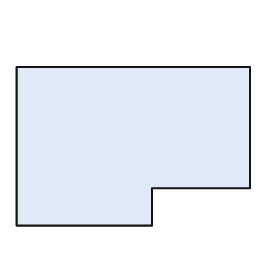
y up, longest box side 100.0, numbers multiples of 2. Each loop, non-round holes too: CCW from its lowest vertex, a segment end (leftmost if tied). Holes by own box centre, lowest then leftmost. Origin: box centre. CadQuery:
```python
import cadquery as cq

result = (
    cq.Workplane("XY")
    .moveTo(-50.0, -34.0)
    .lineTo(8.0, -34.0)
    .lineTo(8.0, -18.0)
    .lineTo(50.0, -18.0)
    .lineTo(50.0, 34.0)
    .lineTo(-50.0, 34.0)
    .close()
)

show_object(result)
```